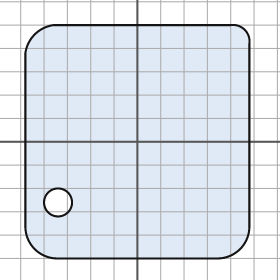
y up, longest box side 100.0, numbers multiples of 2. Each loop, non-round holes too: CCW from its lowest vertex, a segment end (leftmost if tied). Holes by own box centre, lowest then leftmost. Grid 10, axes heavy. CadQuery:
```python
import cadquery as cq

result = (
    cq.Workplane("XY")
    .moveTo(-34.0, -50.0)
    .lineTo(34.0, -50.0)
    .threePointArc((44.0, -46.0), (48.0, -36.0))
    .lineTo(48.0, 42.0)
    .threePointArc((46.0, 48.0), (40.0, 50.0))
    .lineTo(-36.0, 50.0)
    .threePointArc((-44.0, 46.0), (-48.0, 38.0))
    .lineTo(-48.0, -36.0)
    .threePointArc((-44.0, -46.0), (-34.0, -50.0))
    .close()
    .moveTo(-34.0, -26.0)
    .circle(6.0)
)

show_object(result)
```